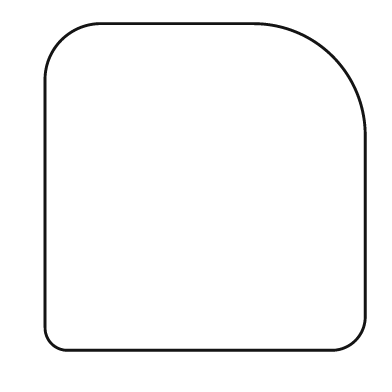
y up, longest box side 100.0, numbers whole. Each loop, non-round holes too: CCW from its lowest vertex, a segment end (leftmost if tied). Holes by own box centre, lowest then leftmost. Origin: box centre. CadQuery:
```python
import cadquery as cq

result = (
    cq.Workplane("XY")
    .moveTo(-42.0, -50.0)
    .lineTo(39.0, -50.0)
    .threePointArc((46.0, -47.0), (49.0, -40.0))
    .lineTo(49.0, 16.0)
    .threePointArc((39.0, 40.0), (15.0, 50.0))
    .lineTo(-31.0, 50.0)
    .threePointArc((-44.0, 45.0), (-49.0, 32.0))
    .lineTo(-49.0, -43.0)
    .threePointArc((-47.0, -48.0), (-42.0, -50.0))
    .close()
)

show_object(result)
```